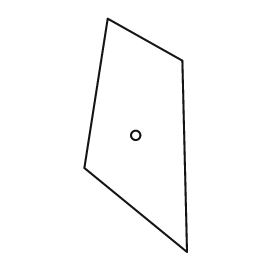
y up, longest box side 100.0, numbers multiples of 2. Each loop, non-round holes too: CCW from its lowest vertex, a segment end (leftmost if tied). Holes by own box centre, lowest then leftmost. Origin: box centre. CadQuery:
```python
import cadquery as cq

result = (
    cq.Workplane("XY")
    .moveTo(22.0, -50.0)
    .lineTo(20.0, 32.0)
    .lineTo(-12.0, 50.0)
    .lineTo(-22.0, -14.0)
    .close()
    .moveTo(0.0, 0.0)
    .circle(2.0)
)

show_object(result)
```